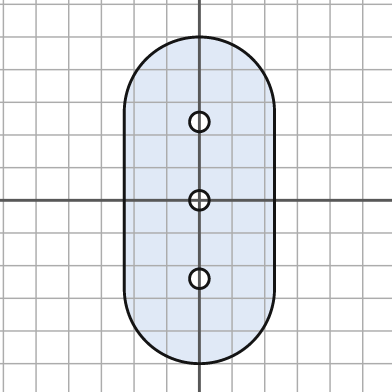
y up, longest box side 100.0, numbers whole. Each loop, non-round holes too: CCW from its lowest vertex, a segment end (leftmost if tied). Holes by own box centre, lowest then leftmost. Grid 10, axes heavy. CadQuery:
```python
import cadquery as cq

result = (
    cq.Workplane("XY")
    .moveTo(-23.0, -27.0)
    .threePointArc((0.0, -50.0), (23.0, -27.0))
    .lineTo(23.0, 27.0)
    .threePointArc((0.0, 50.0), (-23.0, 27.0))
    .close()
    .moveTo(0.0, -24.0)
    .circle(3.0)
    .moveTo(0.0, 0.0)
    .circle(3.0)
    .moveTo(0.0, 24.0)
    .circle(3.0)
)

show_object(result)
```